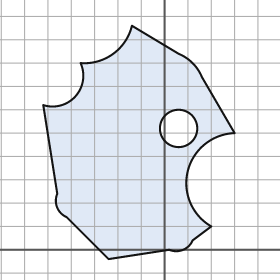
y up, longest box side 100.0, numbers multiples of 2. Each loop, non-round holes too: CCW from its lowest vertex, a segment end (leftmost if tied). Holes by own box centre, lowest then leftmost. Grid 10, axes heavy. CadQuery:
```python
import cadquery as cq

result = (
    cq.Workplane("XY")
    .moveTo(-24.0, -4.0)
    .lineTo(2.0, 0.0)
    .threePointArc((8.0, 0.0), (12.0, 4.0))
    .lineTo(20.0, 10.0)
    .threePointArc((10.0, 34.0), (30.0, 50.0))
    .lineTo(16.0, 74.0)
    .threePointArc((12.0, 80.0), (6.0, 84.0))
    .lineTo(-14.0, 96.0)
    .threePointArc((-22.0, 84.0), (-36.0, 80.0))
    .threePointArc((-38.0, 66.0), (-52.0, 62.0))
    .lineTo(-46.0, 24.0)
    .threePointArc((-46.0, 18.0), (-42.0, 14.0))
    .close()
    .moveTo(6.0, 52.0)
    .circle(8.0)
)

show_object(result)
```